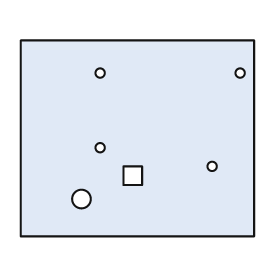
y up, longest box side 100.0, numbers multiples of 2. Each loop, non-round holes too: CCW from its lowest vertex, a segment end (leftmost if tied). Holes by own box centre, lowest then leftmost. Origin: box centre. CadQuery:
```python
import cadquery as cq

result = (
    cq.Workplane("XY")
    .moveTo(-50.0, -42.0)
    .lineTo(50.0, -42.0)
    .lineTo(50.0, 42.0)
    .lineTo(-50.0, 42.0)
    .close()
    .moveTo(-24.0, -26.0)
    .circle(4.0)
    .moveTo(-6.0, -20.0)
    .lineTo(2.0, -20.0)
    .lineTo(2.0, -12.0)
    .lineTo(-6.0, -12.0)
    .close()
    .moveTo(32.0, -12.0)
    .circle(2.0)
    .moveTo(-16.0, -4.0)
    .circle(2.0)
    .moveTo(-16.0, 28.0)
    .circle(2.0)
    .moveTo(44.0, 28.0)
    .circle(2.0)
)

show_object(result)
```